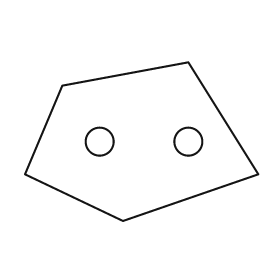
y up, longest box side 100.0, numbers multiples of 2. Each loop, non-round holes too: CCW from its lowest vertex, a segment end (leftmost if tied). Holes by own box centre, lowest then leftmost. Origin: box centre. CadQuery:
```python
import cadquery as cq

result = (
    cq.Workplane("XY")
    .moveTo(-8.0, -34.0)
    .lineTo(50.0, -14.0)
    .lineTo(20.0, 34.0)
    .lineTo(-34.0, 24.0)
    .lineTo(-50.0, -14.0)
    .close()
    .moveTo(-18.0, 0.0)
    .circle(6.0)
    .moveTo(20.0, 0.0)
    .circle(6.0)
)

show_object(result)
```